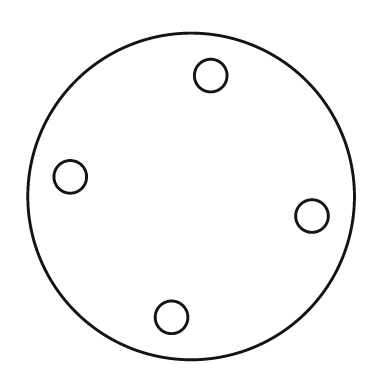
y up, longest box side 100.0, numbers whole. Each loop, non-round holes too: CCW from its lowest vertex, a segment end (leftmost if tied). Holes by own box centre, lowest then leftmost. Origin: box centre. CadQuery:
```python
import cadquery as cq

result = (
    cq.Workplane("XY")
    .moveTo(0.0, 0.0)
    .circle(50.0)
    .moveTo(-6.0, -37.0)
    .circle(5.0)
    .moveTo(37.0, -6.0)
    .circle(5.0)
    .moveTo(-37.0, 6.0)
    .circle(5.0)
    .moveTo(6.0, 37.0)
    .circle(5.0)
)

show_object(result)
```